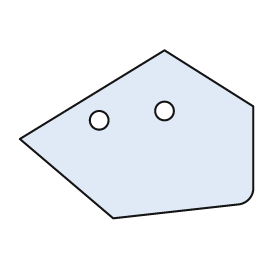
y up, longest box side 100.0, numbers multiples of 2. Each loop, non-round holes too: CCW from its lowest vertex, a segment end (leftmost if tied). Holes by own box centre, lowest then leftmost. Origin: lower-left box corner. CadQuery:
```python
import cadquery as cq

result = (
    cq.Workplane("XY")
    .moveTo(40.0, 0.0)
    .lineTo(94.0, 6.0)
    .threePointArc((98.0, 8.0), (100.0, 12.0))
    .lineTo(100.0, 48.0)
    .lineTo(62.0, 72.0)
    .lineTo(0.0, 34.0)
    .close()
    .moveTo(34.0, 42.0)
    .circle(4.0)
    .moveTo(62.0, 46.0)
    .circle(4.0)
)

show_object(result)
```